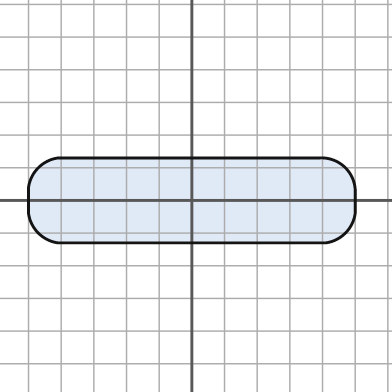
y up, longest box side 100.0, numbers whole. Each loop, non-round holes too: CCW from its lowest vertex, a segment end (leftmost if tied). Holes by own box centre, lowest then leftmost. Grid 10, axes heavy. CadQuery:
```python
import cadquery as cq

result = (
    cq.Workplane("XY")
    .moveTo(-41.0, -13.0)
    .lineTo(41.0, -13.0)
    .threePointArc((47.0, -10.0), (50.0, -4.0))
    .lineTo(50.0, 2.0)
    .threePointArc((47.0, 10.0), (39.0, 13.0))
    .lineTo(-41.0, 13.0)
    .threePointArc((-47.0, 10.0), (-50.0, 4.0))
    .lineTo(-50.0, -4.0)
    .threePointArc((-47.0, -10.0), (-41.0, -13.0))
    .close()
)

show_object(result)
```